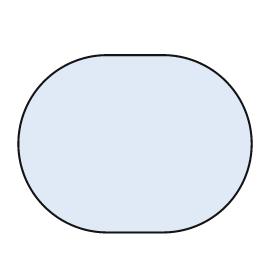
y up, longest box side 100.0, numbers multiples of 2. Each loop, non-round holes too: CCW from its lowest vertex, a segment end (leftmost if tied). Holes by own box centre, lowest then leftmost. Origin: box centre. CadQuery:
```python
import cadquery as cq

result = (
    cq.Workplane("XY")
    .moveTo(-12.0, -38.0)
    .lineTo(12.0, -38.0)
    .threePointArc((50.0, 0.0), (12.0, 38.0))
    .lineTo(-12.0, 38.0)
    .threePointArc((-50.0, 0.0), (-12.0, -38.0))
    .close()
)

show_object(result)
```